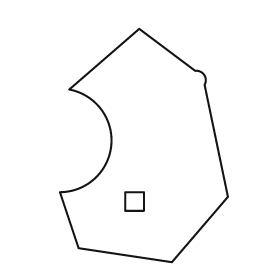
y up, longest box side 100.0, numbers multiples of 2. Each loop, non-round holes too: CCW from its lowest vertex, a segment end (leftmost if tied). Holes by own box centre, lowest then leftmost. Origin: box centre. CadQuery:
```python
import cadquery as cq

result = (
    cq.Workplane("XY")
    .moveTo(12.0, -50.0)
    .lineTo(36.0, -22.0)
    .lineTo(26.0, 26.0)
    .threePointArc((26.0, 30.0), (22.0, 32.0))
    .lineTo(-2.0, 50.0)
    .lineTo(-32.0, 24.0)
    .threePointArc((-14.0, 0.0), (-36.0, -20.0))
    .lineTo(-28.0, -44.0)
    .close()
    .moveTo(-8.0, -28.0)
    .lineTo(0.0, -28.0)
    .lineTo(0.0, -20.0)
    .lineTo(-8.0, -20.0)
    .close()
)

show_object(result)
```